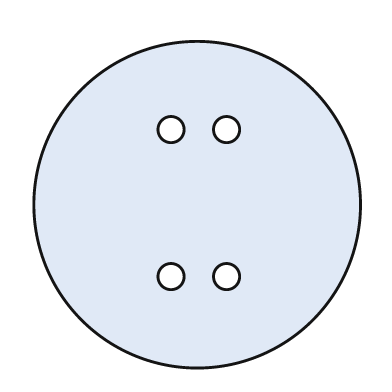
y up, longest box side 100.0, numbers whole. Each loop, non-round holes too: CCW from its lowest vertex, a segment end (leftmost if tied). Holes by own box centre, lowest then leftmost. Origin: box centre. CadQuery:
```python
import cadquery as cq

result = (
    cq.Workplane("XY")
    .moveTo(0.0, 0.0)
    .circle(50.0)
    .moveTo(-8.0, -22.0)
    .circle(4.0)
    .moveTo(9.0, -22.0)
    .circle(4.0)
    .moveTo(-8.0, 23.0)
    .circle(4.0)
    .moveTo(9.0, 23.0)
    .circle(4.0)
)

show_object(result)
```